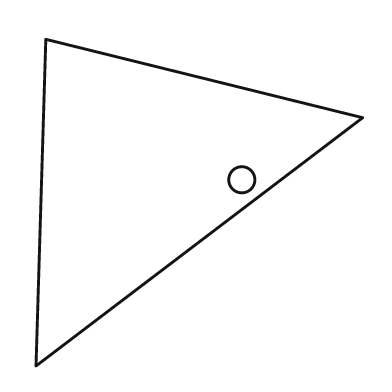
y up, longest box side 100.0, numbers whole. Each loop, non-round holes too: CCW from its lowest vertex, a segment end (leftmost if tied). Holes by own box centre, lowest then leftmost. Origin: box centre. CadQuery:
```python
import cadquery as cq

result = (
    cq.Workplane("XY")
    .moveTo(-50.0, -50.0)
    .lineTo(50.0, 26.0)
    .lineTo(-47.0, 50.0)
    .close()
    .moveTo(13.0, 7.0)
    .circle(4.0)
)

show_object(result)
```